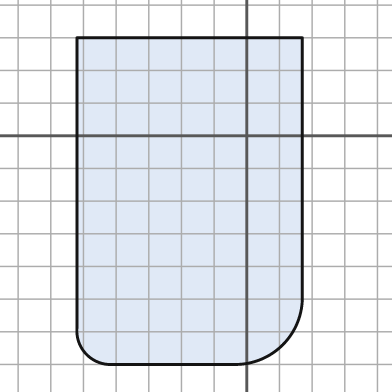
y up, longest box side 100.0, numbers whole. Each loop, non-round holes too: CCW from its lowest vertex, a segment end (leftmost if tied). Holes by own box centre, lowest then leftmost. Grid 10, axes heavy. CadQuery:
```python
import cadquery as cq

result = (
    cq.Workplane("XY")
    .moveTo(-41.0, -70.0)
    .lineTo(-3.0, -70.0)
    .threePointArc((11.0, -64.0), (17.0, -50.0))
    .lineTo(17.0, 30.0)
    .lineTo(-52.0, 30.0)
    .lineTo(-52.0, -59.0)
    .threePointArc((-49.0, -67.0), (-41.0, -70.0))
    .close()
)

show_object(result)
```